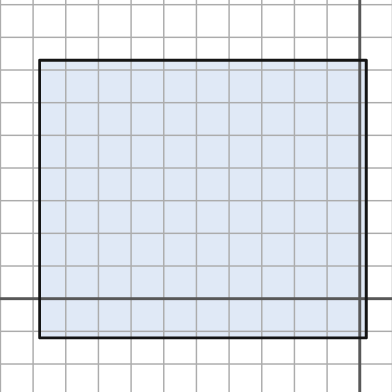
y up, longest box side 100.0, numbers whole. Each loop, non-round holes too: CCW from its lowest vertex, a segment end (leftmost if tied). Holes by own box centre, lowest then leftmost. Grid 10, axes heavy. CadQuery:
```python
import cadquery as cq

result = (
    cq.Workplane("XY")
    .moveTo(-98.0, -12.0)
    .lineTo(2.0, -12.0)
    .lineTo(2.0, 73.0)
    .lineTo(-98.0, 73.0)
    .close()
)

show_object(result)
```